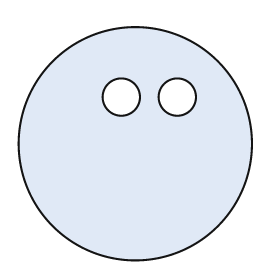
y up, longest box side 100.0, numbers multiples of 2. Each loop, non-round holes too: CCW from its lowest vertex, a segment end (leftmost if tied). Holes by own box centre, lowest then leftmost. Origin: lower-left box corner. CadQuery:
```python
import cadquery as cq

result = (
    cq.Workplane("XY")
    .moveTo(50.0, 50.0)
    .circle(50.0)
    .moveTo(44.0, 70.0)
    .circle(8.0)
    .moveTo(68.0, 70.0)
    .circle(8.0)
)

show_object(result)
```